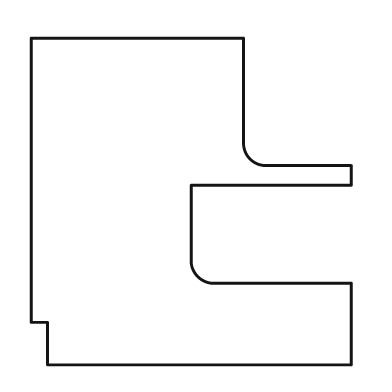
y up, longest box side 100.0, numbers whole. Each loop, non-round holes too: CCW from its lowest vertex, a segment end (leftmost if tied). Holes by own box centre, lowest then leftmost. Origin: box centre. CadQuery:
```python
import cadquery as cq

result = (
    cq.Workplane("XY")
    .moveTo(-44.0, -50.0)
    .lineTo(49.0, -50.0)
    .lineTo(49.0, -25.0)
    .lineTo(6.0, -25.0)
    .threePointArc((2.0, -23.0), (0.0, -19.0))
    .lineTo(0.0, 5.0)
    .lineTo(49.0, 5.0)
    .lineTo(49.0, 11.0)
    .lineTo(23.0, 11.0)
    .threePointArc((18.0, 13.0), (16.0, 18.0))
    .lineTo(16.0, 50.0)
    .lineTo(-49.0, 50.0)
    .lineTo(-49.0, -37.0)
    .lineTo(-44.0, -37.0)
    .close()
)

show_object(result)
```